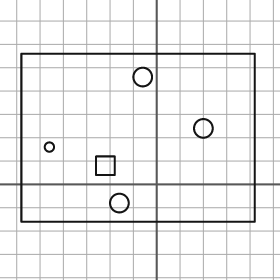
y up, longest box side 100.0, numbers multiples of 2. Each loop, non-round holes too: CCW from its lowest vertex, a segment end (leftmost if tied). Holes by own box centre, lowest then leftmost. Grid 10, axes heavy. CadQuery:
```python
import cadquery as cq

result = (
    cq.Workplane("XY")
    .moveTo(-58.0, -16.0)
    .lineTo(42.0, -16.0)
    .lineTo(42.0, 56.0)
    .lineTo(-58.0, 56.0)
    .close()
    .moveTo(-16.0, -8.0)
    .circle(4.0)
    .moveTo(-26.0, 4.0)
    .lineTo(-18.0, 4.0)
    .lineTo(-18.0, 12.0)
    .lineTo(-26.0, 12.0)
    .close()
    .moveTo(-46.0, 16.0)
    .circle(2.0)
    .moveTo(20.0, 24.0)
    .circle(4.0)
    .moveTo(-6.0, 46.0)
    .circle(4.0)
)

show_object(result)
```